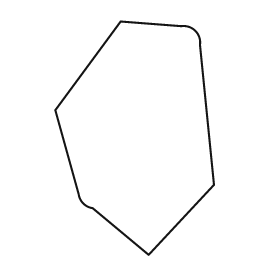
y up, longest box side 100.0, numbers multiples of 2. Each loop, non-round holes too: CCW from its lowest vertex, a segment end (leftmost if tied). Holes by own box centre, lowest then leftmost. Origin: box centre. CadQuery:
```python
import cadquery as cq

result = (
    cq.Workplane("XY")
    .moveTo(6.0, -50.0)
    .lineTo(34.0, -20.0)
    .lineTo(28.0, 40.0)
    .threePointArc((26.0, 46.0), (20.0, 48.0))
    .lineTo(-6.0, 50.0)
    .lineTo(-34.0, 12.0)
    .lineTo(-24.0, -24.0)
    .threePointArc((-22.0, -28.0), (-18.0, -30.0))
    .close()
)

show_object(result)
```